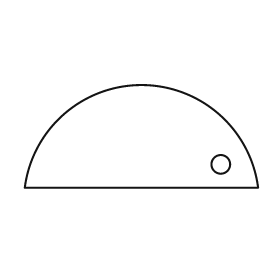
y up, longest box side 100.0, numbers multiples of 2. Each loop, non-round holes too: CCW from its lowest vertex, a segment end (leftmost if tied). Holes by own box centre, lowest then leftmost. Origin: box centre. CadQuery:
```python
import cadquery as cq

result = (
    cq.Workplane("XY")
    .moveTo(-50.0, -22.0)
    .lineTo(50.0, -22.0)
    .threePointArc((0.0, 22.0), (-50.0, -22.0))
    .close()
    .moveTo(34.0, -12.0)
    .circle(4.0)
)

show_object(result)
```